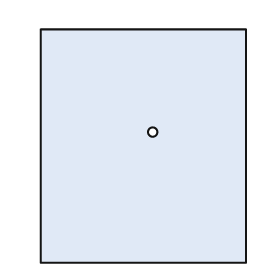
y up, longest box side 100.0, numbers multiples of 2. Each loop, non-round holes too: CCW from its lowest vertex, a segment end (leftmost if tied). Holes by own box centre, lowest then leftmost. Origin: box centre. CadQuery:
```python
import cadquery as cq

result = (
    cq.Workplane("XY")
    .moveTo(-44.0, -50.0)
    .lineTo(44.0, -50.0)
    .lineTo(44.0, 50.0)
    .lineTo(-44.0, 50.0)
    .close()
    .moveTo(4.0, 6.0)
    .circle(2.0)
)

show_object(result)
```